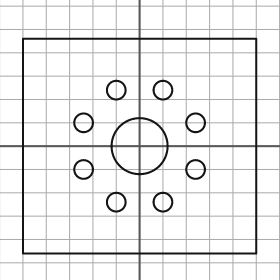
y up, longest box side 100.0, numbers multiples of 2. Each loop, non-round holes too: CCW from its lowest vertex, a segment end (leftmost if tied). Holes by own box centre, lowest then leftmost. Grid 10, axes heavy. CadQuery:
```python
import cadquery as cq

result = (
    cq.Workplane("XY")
    .moveTo(-50.0, -46.0)
    .lineTo(50.0, -46.0)
    .lineTo(50.0, 46.0)
    .lineTo(-50.0, 46.0)
    .close()
    .moveTo(-10.0, -24.0)
    .circle(4.0)
    .moveTo(10.0, -24.0)
    .circle(4.0)
    .moveTo(-24.0, -10.0)
    .circle(4.0)
    .moveTo(24.0, -10.0)
    .circle(4.0)
    .moveTo(0.0, 0.0)
    .circle(12.0)
    .moveTo(-24.0, 10.0)
    .circle(4.0)
    .moveTo(24.0, 10.0)
    .circle(4.0)
    .moveTo(-10.0, 24.0)
    .circle(4.0)
    .moveTo(10.0, 24.0)
    .circle(4.0)
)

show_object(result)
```